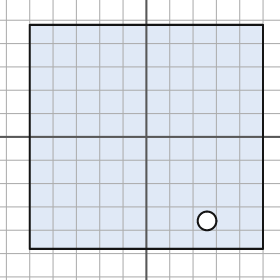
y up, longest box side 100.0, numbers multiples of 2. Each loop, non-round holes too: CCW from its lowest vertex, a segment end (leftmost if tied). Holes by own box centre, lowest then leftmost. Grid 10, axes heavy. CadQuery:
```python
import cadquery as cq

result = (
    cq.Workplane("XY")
    .moveTo(-50.0, -48.0)
    .lineTo(50.0, -48.0)
    .lineTo(50.0, 48.0)
    .lineTo(-50.0, 48.0)
    .close()
    .moveTo(26.0, -36.0)
    .circle(4.0)
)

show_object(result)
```